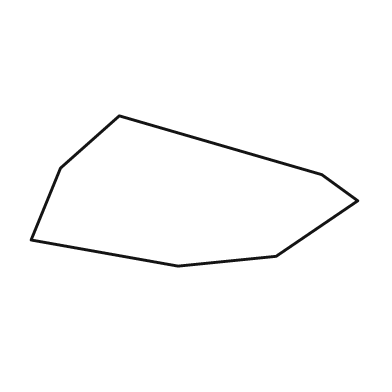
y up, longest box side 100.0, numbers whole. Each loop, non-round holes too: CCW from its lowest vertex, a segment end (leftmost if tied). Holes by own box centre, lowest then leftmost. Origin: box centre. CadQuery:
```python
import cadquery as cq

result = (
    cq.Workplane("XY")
    .moveTo(-5.0, -23.0)
    .lineTo(25.0, -20.0)
    .lineTo(50.0, -3.0)
    .lineTo(39.0, 5.0)
    .lineTo(-23.0, 23.0)
    .lineTo(-41.0, 7.0)
    .lineTo(-50.0, -15.0)
    .close()
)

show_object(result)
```